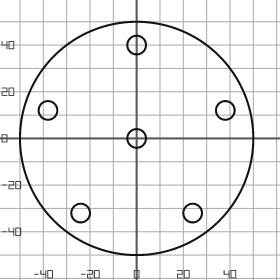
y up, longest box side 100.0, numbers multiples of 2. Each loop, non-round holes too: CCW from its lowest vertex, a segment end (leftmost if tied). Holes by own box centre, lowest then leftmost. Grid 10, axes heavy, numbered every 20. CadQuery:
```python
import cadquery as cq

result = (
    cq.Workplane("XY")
    .moveTo(0.0, 0.0)
    .circle(50.0)
    .moveTo(-24.0, -32.0)
    .circle(4.0)
    .moveTo(24.0, -32.0)
    .circle(4.0)
    .moveTo(0.0, 0.0)
    .circle(4.0)
    .moveTo(-38.0, 12.0)
    .circle(4.0)
    .moveTo(38.0, 12.0)
    .circle(4.0)
    .moveTo(0.0, 40.0)
    .circle(4.0)
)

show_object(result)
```